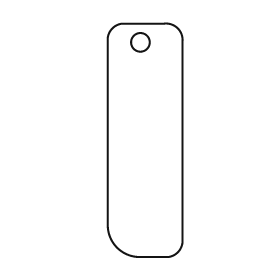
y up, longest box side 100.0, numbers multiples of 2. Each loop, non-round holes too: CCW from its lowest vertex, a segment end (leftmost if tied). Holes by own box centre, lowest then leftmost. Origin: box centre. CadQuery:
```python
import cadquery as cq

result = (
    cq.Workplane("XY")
    .moveTo(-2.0, -50.0)
    .lineTo(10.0, -50.0)
    .threePointArc((14.0, -48.0), (16.0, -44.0))
    .lineTo(16.0, 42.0)
    .threePointArc((14.0, 48.0), (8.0, 50.0))
    .lineTo(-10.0, 50.0)
    .threePointArc((-14.0, 48.0), (-16.0, 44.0))
    .lineTo(-16.0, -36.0)
    .threePointArc((-12.0, -46.0), (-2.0, -50.0))
    .close()
    .moveTo(-2.0, 42.0)
    .circle(4.0)
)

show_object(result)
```